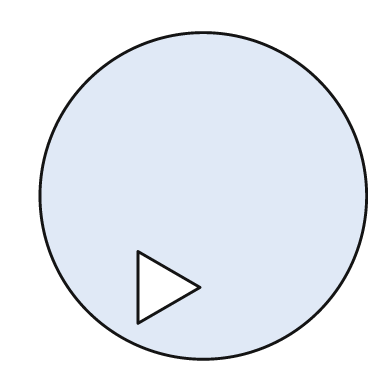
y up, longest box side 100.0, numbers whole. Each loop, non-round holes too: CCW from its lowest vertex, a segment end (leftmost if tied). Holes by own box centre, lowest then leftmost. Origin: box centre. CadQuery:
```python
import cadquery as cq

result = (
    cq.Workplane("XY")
    .moveTo(0.0, 0.0)
    .circle(50.0)
    .moveTo(-20.0, -39.0)
    .lineTo(-1.0, -28.0)
    .lineTo(-20.0, -17.0)
    .close()
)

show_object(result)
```